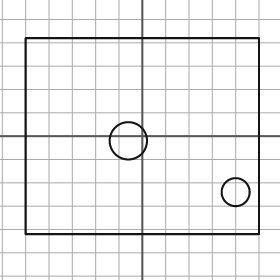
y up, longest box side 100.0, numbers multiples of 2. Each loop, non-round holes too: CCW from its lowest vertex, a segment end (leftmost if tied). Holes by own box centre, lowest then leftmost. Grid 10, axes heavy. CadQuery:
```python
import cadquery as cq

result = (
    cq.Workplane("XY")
    .moveTo(-50.0, -42.0)
    .lineTo(50.0, -42.0)
    .lineTo(50.0, 42.0)
    .lineTo(-50.0, 42.0)
    .close()
    .moveTo(40.0, -24.0)
    .circle(6.0)
    .moveTo(-6.0, -2.0)
    .circle(8.0)
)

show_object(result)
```